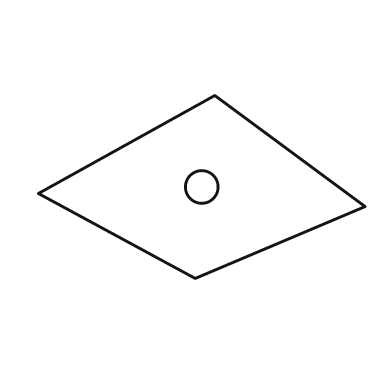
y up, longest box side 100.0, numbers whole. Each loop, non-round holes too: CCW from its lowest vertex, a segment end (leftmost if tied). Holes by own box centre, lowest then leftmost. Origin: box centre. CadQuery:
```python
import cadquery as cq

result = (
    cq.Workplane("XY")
    .moveTo(-2.0, -28.0)
    .lineTo(50.0, -6.0)
    .lineTo(4.0, 28.0)
    .lineTo(-50.0, -2.0)
    .close()
    .moveTo(0.0, 0.0)
    .circle(5.0)
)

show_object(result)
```